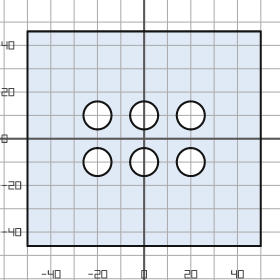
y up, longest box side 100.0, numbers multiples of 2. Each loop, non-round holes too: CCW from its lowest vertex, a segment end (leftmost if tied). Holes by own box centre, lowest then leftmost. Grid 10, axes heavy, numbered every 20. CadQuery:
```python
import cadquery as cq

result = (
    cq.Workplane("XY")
    .moveTo(-50.0, -46.0)
    .lineTo(50.0, -46.0)
    .lineTo(50.0, 46.0)
    .lineTo(-50.0, 46.0)
    .close()
    .moveTo(-20.0, -10.0)
    .circle(6.0)
    .moveTo(0.0, -10.0)
    .circle(6.0)
    .moveTo(20.0, -10.0)
    .circle(6.0)
    .moveTo(-20.0, 10.0)
    .circle(6.0)
    .moveTo(0.0, 10.0)
    .circle(6.0)
    .moveTo(20.0, 10.0)
    .circle(6.0)
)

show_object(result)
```